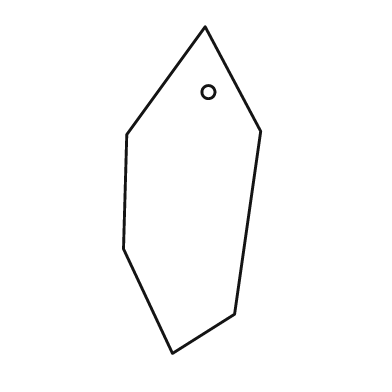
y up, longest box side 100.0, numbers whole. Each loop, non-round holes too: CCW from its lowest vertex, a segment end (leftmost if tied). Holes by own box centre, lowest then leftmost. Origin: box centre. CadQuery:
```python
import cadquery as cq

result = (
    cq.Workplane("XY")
    .moveTo(-6.0, -50.0)
    .lineTo(13.0, -38.0)
    .lineTo(21.0, 18.0)
    .lineTo(4.0, 50.0)
    .lineTo(-20.0, 17.0)
    .lineTo(-21.0, -18.0)
    .close()
    .moveTo(5.0, 30.0)
    .circle(2.0)
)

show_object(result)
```